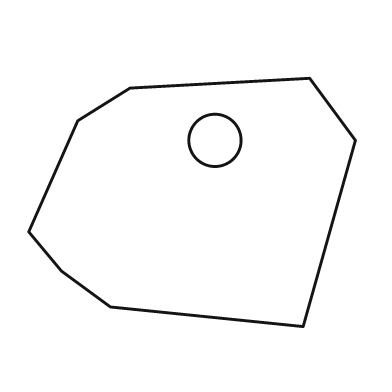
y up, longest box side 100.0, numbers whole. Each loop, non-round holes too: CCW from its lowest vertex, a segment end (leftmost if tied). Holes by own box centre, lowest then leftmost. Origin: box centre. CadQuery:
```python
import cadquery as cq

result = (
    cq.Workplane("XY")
    .moveTo(34.0, -38.0)
    .lineTo(50.0, 19.0)
    .lineTo(36.0, 38.0)
    .lineTo(-19.0, 35.0)
    .lineTo(-35.0, 25.0)
    .lineTo(-50.0, -9.0)
    .lineTo(-40.0, -21.0)
    .lineTo(-25.0, -32.0)
    .close()
    .moveTo(7.0, 19.0)
    .circle(8.0)
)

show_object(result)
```